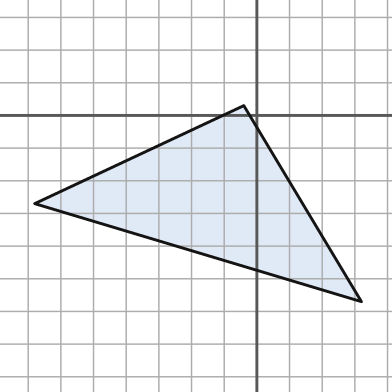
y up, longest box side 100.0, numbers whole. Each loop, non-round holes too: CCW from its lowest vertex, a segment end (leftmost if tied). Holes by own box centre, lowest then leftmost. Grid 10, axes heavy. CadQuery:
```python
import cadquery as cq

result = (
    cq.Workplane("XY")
    .moveTo(32.0, -57.0)
    .lineTo(-4.0, 3.0)
    .lineTo(-68.0, -27.0)
    .close()
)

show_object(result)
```